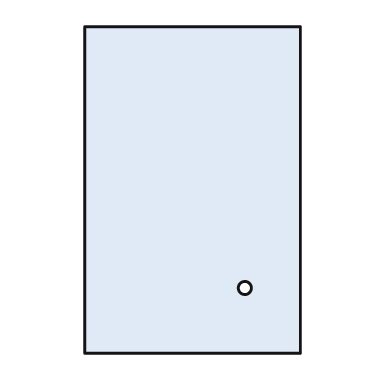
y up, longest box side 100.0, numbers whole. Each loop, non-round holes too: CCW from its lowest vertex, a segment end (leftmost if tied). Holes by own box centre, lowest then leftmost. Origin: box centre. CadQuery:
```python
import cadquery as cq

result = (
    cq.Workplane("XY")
    .moveTo(-33.0, -50.0)
    .lineTo(33.0, -50.0)
    .lineTo(33.0, 50.0)
    .lineTo(-33.0, 50.0)
    .close()
    .moveTo(16.0, -30.0)
    .circle(2.0)
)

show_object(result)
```